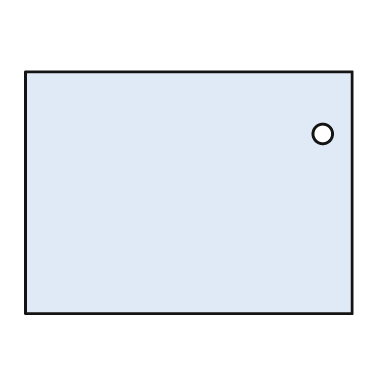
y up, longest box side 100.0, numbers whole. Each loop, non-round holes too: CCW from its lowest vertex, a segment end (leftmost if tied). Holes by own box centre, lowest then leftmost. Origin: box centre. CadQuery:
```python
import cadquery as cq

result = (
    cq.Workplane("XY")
    .moveTo(-50.0, -37.0)
    .lineTo(50.0, -37.0)
    .lineTo(50.0, 37.0)
    .lineTo(-50.0, 37.0)
    .close()
    .moveTo(41.0, 18.0)
    .circle(3.0)
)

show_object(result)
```